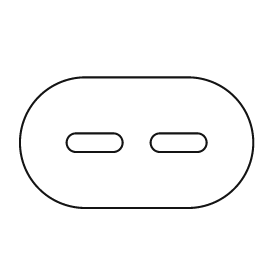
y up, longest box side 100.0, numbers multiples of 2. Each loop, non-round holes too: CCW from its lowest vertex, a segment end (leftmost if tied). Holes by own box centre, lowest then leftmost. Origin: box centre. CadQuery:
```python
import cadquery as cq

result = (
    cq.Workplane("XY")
    .moveTo(-22.0, -28.0)
    .lineTo(22.0, -28.0)
    .threePointArc((50.0, 0.0), (22.0, 28.0))
    .lineTo(-22.0, 28.0)
    .threePointArc((-50.0, 0.0), (-22.0, -28.0))
    .close()
    .moveTo(-26.0, -4.0)
    .lineTo(-10.0, -4.0)
    .threePointArc((-6.0, 0.0), (-10.0, 4.0))
    .lineTo(-26.0, 4.0)
    .threePointArc((-30.0, 0.0), (-26.0, -4.0))
    .close()
    .moveTo(10.0, -4.0)
    .lineTo(26.0, -4.0)
    .threePointArc((30.0, 0.0), (26.0, 4.0))
    .lineTo(10.0, 4.0)
    .threePointArc((6.0, 0.0), (10.0, -4.0))
    .close()
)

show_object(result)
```